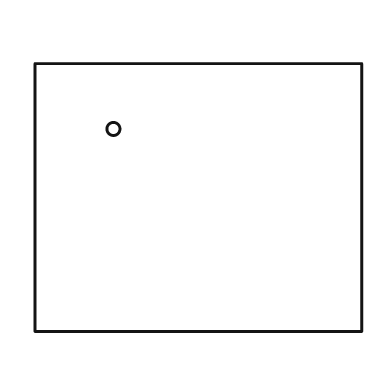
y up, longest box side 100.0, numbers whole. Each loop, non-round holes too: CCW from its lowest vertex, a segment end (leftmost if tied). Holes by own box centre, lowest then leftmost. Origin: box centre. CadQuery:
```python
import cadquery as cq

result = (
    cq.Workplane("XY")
    .moveTo(-50.0, -41.0)
    .lineTo(50.0, -41.0)
    .lineTo(50.0, 41.0)
    .lineTo(-50.0, 41.0)
    .close()
    .moveTo(-26.0, 21.0)
    .circle(2.0)
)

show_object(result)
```